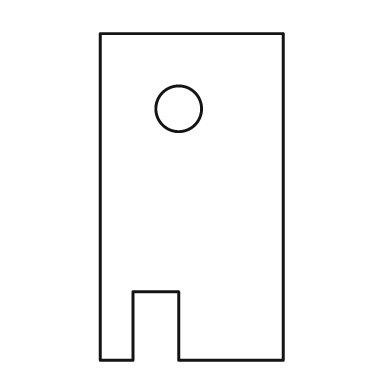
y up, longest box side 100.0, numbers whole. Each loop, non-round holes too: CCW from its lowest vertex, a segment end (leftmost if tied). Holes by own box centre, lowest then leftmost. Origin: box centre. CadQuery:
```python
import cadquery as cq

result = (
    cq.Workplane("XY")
    .moveTo(-28.0, -50.0)
    .lineTo(-18.0, -50.0)
    .lineTo(-18.0, -29.0)
    .lineTo(-4.0, -29.0)
    .lineTo(-4.0, -50.0)
    .lineTo(28.0, -50.0)
    .lineTo(28.0, 50.0)
    .lineTo(-28.0, 50.0)
    .close()
    .moveTo(-4.0, 27.0)
    .circle(7.0)
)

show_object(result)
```